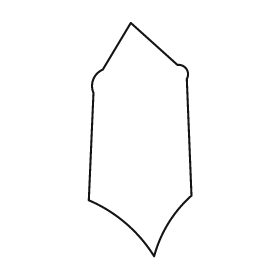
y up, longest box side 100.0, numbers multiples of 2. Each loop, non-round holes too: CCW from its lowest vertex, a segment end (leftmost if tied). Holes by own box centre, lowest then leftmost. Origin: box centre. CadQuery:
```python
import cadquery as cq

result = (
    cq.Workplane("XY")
    .moveTo(6.0, -50.0)
    .threePointArc((12.0, -36.0), (22.0, -24.0))
    .lineTo(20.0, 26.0)
    .threePointArc((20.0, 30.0), (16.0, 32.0))
    .lineTo(-4.0, 50.0)
    .lineTo(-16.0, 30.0)
    .threePointArc((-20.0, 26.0), (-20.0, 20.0))
    .lineTo(-22.0, -26.0)
    .threePointArc((-6.0, -36.0), (6.0, -50.0))
    .close()
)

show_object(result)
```